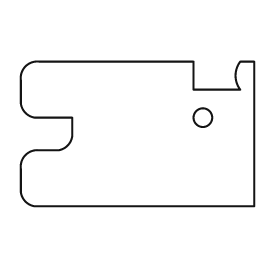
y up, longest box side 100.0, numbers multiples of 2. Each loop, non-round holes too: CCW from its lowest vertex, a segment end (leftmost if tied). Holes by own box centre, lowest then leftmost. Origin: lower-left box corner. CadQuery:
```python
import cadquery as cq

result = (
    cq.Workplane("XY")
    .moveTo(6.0, 0.0)
    .lineTo(100.0, 0.0)
    .lineTo(100.0, 62.0)
    .lineTo(94.0, 62.0)
    .threePointArc((92.0, 56.0), (94.0, 50.0))
    .lineTo(74.0, 50.0)
    .lineTo(74.0, 62.0)
    .lineTo(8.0, 62.0)
    .threePointArc((2.0, 60.0), (0.0, 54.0))
    .lineTo(0.0, 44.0)
    .threePointArc((2.0, 40.0), (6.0, 38.0))
    .lineTo(22.0, 38.0)
    .lineTo(22.0, 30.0)
    .threePointArc((20.0, 26.0), (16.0, 24.0))
    .lineTo(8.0, 24.0)
    .threePointArc((2.0, 22.0), (0.0, 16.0))
    .lineTo(0.0, 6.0)
    .threePointArc((2.0, 2.0), (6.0, 0.0))
    .close()
    .moveTo(78.0, 38.0)
    .circle(4.0)
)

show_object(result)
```